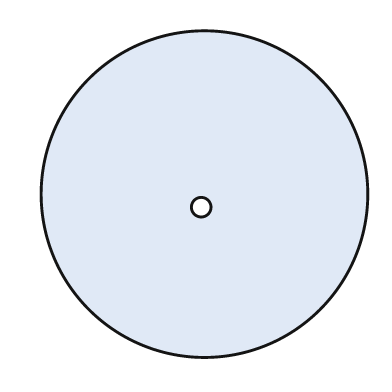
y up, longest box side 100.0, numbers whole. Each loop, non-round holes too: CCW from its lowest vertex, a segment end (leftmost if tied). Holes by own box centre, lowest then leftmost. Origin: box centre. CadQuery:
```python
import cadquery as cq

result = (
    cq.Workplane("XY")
    .moveTo(0.0, 0.0)
    .circle(50.0)
    .moveTo(-1.0, -4.0)
    .circle(3.0)
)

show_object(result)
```